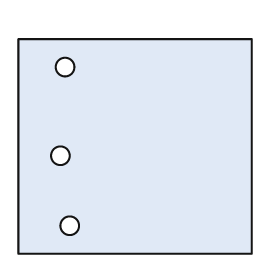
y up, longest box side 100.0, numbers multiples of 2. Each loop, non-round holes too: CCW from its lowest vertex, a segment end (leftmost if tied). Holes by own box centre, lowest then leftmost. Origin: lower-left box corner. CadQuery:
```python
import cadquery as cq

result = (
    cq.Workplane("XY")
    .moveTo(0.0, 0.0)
    .lineTo(100.0, 0.0)
    .lineTo(100.0, 92.0)
    .lineTo(0.0, 92.0)
    .close()
    .moveTo(22.0, 12.0)
    .circle(4.0)
    .moveTo(18.0, 42.0)
    .circle(4.0)
    .moveTo(20.0, 80.0)
    .circle(4.0)
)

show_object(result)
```